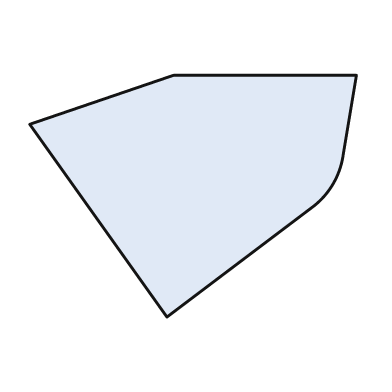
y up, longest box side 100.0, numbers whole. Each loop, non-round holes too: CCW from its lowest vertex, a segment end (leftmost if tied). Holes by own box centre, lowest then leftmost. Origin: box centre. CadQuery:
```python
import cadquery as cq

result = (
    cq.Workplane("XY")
    .moveTo(-8.0, -37.0)
    .lineTo(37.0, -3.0)
    .threePointArc((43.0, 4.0), (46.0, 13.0))
    .lineTo(50.0, 37.0)
    .lineTo(-6.0, 37.0)
    .lineTo(-50.0, 22.0)
    .close()
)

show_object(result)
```